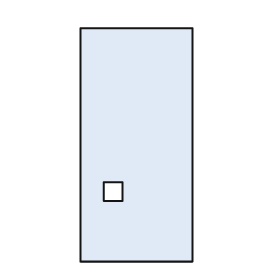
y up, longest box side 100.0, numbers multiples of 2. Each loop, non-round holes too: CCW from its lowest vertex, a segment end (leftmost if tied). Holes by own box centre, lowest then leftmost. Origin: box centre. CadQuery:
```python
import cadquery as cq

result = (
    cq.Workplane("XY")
    .moveTo(-24.0, -50.0)
    .lineTo(24.0, -50.0)
    .lineTo(24.0, 50.0)
    .lineTo(-24.0, 50.0)
    .close()
    .moveTo(-14.0, -24.0)
    .lineTo(-6.0, -24.0)
    .lineTo(-6.0, -16.0)
    .lineTo(-14.0, -16.0)
    .close()
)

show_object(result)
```